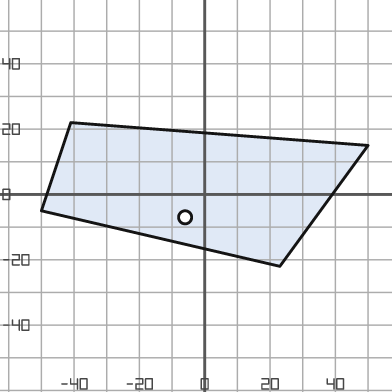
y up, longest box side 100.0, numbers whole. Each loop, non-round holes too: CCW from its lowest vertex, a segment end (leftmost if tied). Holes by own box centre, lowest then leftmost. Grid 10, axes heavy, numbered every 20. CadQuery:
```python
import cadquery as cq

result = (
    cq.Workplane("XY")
    .moveTo(23.0, -22.0)
    .lineTo(50.0, 15.0)
    .lineTo(-41.0, 22.0)
    .lineTo(-50.0, -5.0)
    .close()
    .moveTo(-6.0, -7.0)
    .circle(2.0)
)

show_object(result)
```